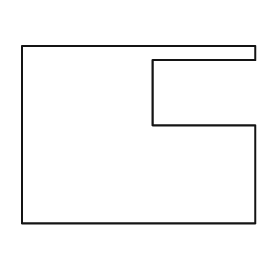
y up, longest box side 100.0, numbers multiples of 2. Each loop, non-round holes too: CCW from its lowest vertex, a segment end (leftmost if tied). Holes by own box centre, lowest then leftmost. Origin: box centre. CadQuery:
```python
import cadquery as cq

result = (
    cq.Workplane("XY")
    .moveTo(-50.0, -38.0)
    .lineTo(50.0, -38.0)
    .lineTo(50.0, 4.0)
    .lineTo(6.0, 4.0)
    .lineTo(6.0, 32.0)
    .lineTo(50.0, 32.0)
    .lineTo(50.0, 38.0)
    .lineTo(-50.0, 38.0)
    .close()
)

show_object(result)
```